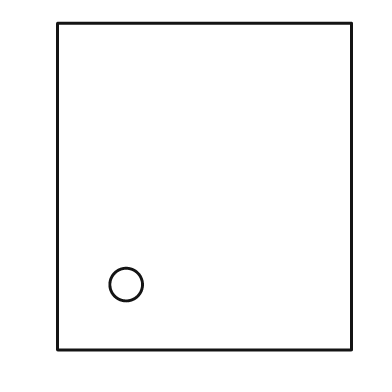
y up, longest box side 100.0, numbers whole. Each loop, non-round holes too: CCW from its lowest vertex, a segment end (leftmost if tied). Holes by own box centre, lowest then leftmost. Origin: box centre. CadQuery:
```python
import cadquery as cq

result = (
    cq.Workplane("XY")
    .moveTo(-45.0, -50.0)
    .lineTo(45.0, -50.0)
    .lineTo(45.0, 50.0)
    .lineTo(-45.0, 50.0)
    .close()
    .moveTo(-24.0, -30.0)
    .circle(5.0)
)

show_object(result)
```